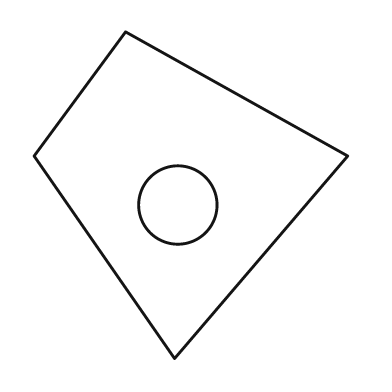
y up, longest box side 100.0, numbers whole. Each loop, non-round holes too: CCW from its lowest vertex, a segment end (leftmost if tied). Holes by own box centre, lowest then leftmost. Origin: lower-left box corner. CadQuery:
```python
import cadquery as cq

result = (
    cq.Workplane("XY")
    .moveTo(43.0, 0.0)
    .lineTo(96.0, 62.0)
    .lineTo(28.0, 100.0)
    .lineTo(0.0, 62.0)
    .close()
    .moveTo(44.0, 47.0)
    .circle(12.0)
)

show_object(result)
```